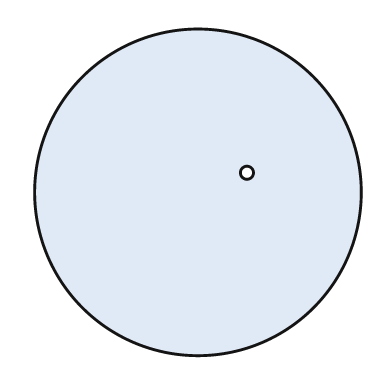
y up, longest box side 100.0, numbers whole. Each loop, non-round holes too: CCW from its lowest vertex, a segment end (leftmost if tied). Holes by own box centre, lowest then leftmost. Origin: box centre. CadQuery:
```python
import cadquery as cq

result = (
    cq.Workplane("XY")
    .moveTo(0.0, 0.0)
    .circle(50.0)
    .moveTo(15.0, 6.0)
    .circle(2.0)
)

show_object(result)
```